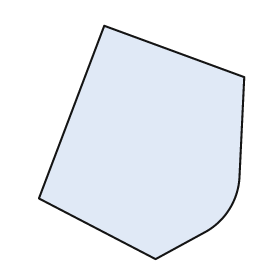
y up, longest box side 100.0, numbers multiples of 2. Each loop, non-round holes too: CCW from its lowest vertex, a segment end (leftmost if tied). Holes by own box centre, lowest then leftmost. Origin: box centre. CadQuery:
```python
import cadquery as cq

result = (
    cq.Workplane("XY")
    .moveTo(6.0, -50.0)
    .lineTo(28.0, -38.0)
    .threePointArc((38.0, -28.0), (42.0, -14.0))
    .lineTo(44.0, 28.0)
    .lineTo(-16.0, 50.0)
    .lineTo(-44.0, -24.0)
    .close()
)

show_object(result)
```